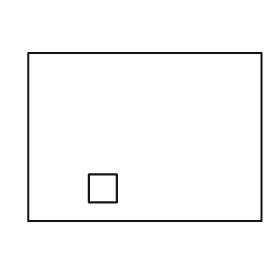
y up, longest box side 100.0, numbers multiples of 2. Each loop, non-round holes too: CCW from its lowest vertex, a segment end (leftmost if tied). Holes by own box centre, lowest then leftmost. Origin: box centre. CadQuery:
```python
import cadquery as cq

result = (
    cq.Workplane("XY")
    .moveTo(-50.0, -36.0)
    .lineTo(50.0, -36.0)
    .lineTo(50.0, 36.0)
    .lineTo(-50.0, 36.0)
    .close()
    .moveTo(-24.0, -28.0)
    .lineTo(-12.0, -28.0)
    .lineTo(-12.0, -16.0)
    .lineTo(-24.0, -16.0)
    .close()
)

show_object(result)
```